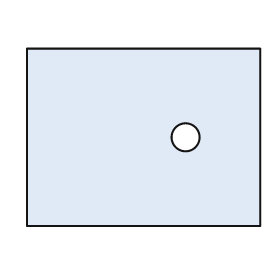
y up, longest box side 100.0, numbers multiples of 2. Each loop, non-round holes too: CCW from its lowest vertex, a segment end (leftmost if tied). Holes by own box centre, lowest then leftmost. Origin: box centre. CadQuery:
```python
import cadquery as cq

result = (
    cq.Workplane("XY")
    .moveTo(-50.0, -38.0)
    .lineTo(50.0, -38.0)
    .lineTo(50.0, 38.0)
    .lineTo(-50.0, 38.0)
    .close()
    .moveTo(18.0, 0.0)
    .circle(6.0)
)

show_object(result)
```